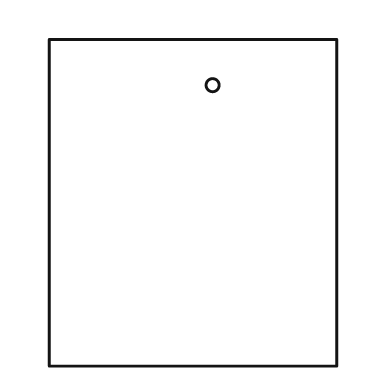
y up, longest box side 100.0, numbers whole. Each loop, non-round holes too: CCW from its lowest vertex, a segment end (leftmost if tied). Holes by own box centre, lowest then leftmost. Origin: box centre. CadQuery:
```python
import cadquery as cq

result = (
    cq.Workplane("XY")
    .moveTo(-44.0, -50.0)
    .lineTo(44.0, -50.0)
    .lineTo(44.0, 50.0)
    .lineTo(-44.0, 50.0)
    .close()
    .moveTo(6.0, 36.0)
    .circle(2.0)
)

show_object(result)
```